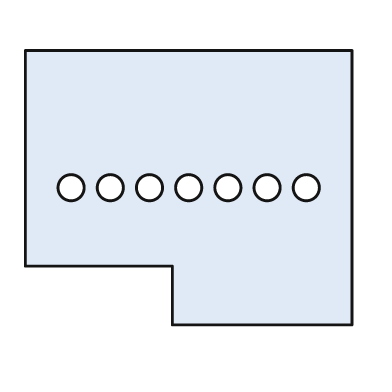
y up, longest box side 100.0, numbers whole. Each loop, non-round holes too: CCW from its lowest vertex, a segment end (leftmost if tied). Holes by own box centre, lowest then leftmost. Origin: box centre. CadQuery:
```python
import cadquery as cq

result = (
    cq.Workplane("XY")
    .moveTo(-5.0, -42.0)
    .lineTo(50.0, -42.0)
    .lineTo(50.0, 42.0)
    .lineTo(-50.0, 42.0)
    .lineTo(-50.0, -24.0)
    .lineTo(-5.0, -24.0)
    .close()
    .moveTo(-36.0, 0.0)
    .circle(4.0)
    .moveTo(-24.0, 0.0)
    .circle(4.0)
    .moveTo(-12.0, 0.0)
    .circle(4.0)
    .moveTo(0.0, 0.0)
    .circle(4.0)
    .moveTo(12.0, 0.0)
    .circle(4.0)
    .moveTo(24.0, 0.0)
    .circle(4.0)
    .moveTo(36.0, 0.0)
    .circle(4.0)
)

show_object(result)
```